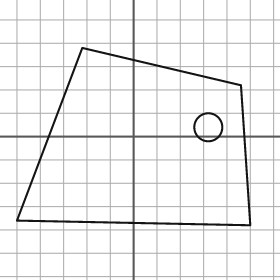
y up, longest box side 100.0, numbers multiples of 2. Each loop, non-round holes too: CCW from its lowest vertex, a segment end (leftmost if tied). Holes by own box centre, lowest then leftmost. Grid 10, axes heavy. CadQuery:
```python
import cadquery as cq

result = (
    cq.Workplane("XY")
    .moveTo(50.0, -38.0)
    .lineTo(46.0, 22.0)
    .lineTo(-22.0, 38.0)
    .lineTo(-50.0, -36.0)
    .close()
    .moveTo(32.0, 4.0)
    .circle(6.0)
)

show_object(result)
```